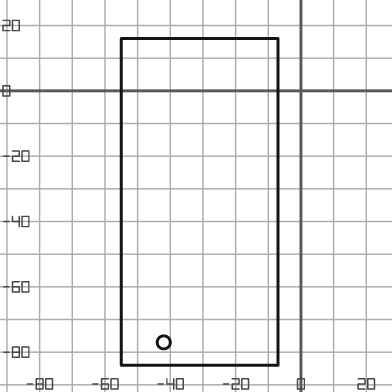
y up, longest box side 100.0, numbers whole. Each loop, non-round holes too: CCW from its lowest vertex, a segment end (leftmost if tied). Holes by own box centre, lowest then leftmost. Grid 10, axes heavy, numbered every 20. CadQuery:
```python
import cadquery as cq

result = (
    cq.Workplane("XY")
    .moveTo(-55.0, -84.0)
    .lineTo(-7.0, -84.0)
    .lineTo(-7.0, 16.0)
    .lineTo(-55.0, 16.0)
    .close()
    .moveTo(-42.0, -77.0)
    .circle(2.0)
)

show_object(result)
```